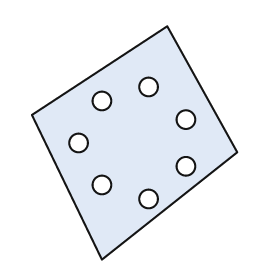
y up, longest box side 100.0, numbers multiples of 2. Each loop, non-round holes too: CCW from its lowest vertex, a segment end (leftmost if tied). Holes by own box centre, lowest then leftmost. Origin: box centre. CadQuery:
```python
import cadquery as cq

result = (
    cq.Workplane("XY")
    .moveTo(-14.0, -50.0)
    .lineTo(44.0, -4.0)
    .lineTo(14.0, 50.0)
    .lineTo(-44.0, 12.0)
    .close()
    .moveTo(6.0, -24.0)
    .circle(4.0)
    .moveTo(-14.0, -18.0)
    .circle(4.0)
    .moveTo(22.0, -10.0)
    .circle(4.0)
    .moveTo(-24.0, 0.0)
    .circle(4.0)
    .moveTo(22.0, 10.0)
    .circle(4.0)
    .moveTo(-14.0, 18.0)
    .circle(4.0)
    .moveTo(6.0, 24.0)
    .circle(4.0)
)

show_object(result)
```